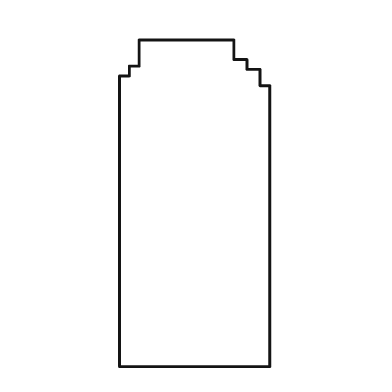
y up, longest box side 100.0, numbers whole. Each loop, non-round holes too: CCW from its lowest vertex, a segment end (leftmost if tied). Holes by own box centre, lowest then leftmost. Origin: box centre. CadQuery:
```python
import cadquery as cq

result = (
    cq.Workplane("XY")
    .moveTo(-23.0, -50.0)
    .lineTo(23.0, -50.0)
    .lineTo(23.0, 36.0)
    .lineTo(20.0, 36.0)
    .lineTo(20.0, 41.0)
    .lineTo(16.0, 41.0)
    .lineTo(16.0, 44.0)
    .lineTo(12.0, 44.0)
    .lineTo(12.0, 50.0)
    .lineTo(-17.0, 50.0)
    .lineTo(-17.0, 42.0)
    .lineTo(-20.0, 42.0)
    .lineTo(-20.0, 39.0)
    .lineTo(-23.0, 39.0)
    .close()
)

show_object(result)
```